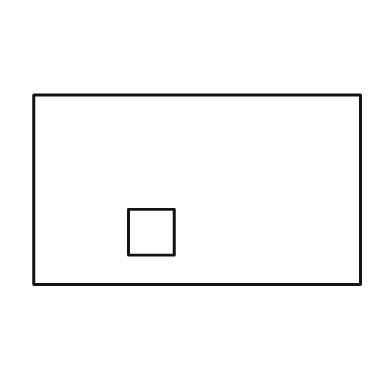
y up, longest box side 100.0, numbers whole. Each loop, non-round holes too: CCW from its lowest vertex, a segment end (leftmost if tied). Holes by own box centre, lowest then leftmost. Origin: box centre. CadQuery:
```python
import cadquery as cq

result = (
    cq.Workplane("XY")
    .moveTo(-50.0, -29.0)
    .lineTo(50.0, -29.0)
    .lineTo(50.0, 29.0)
    .lineTo(-50.0, 29.0)
    .close()
    .moveTo(-21.0, -20.0)
    .lineTo(-7.0, -20.0)
    .lineTo(-7.0, -6.0)
    .lineTo(-21.0, -6.0)
    .close()
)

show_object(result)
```